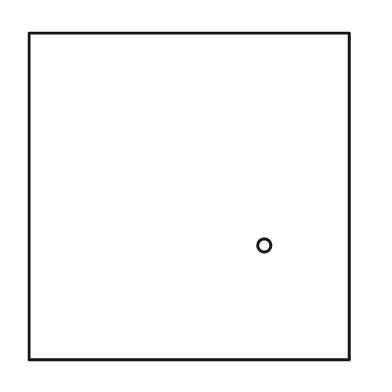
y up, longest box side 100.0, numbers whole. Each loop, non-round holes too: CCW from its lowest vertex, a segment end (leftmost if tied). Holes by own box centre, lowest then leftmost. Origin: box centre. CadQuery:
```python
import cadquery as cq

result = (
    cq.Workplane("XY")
    .moveTo(-49.0, -50.0)
    .lineTo(49.0, -50.0)
    .lineTo(49.0, 50.0)
    .lineTo(-49.0, 50.0)
    .close()
    .moveTo(23.0, -15.0)
    .circle(2.0)
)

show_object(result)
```